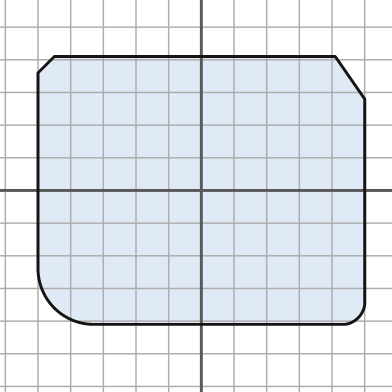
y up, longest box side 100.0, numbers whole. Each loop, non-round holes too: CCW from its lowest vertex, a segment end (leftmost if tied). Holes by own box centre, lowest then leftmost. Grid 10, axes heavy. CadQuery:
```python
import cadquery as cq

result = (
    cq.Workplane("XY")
    .moveTo(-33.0, -41.0)
    .lineTo(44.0, -41.0)
    .threePointArc((48.0, -39.0), (50.0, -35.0))
    .lineTo(50.0, 28.0)
    .lineTo(41.0, 41.0)
    .lineTo(-45.0, 41.0)
    .lineTo(-50.0, 36.0)
    .lineTo(-50.0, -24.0)
    .threePointArc((-45.0, -36.0), (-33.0, -41.0))
    .close()
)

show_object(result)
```